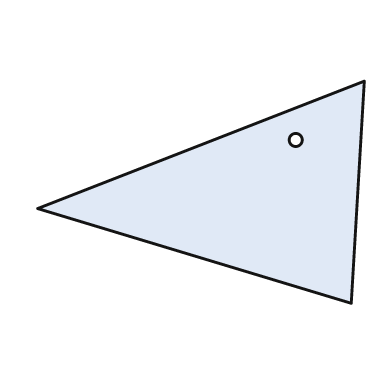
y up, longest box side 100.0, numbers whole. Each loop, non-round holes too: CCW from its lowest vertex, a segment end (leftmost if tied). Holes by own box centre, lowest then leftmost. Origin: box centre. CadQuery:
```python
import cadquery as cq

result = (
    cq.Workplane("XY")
    .moveTo(46.0, -34.0)
    .lineTo(50.0, 34.0)
    .lineTo(-50.0, -5.0)
    .close()
    .moveTo(29.0, 16.0)
    .circle(2.0)
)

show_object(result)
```